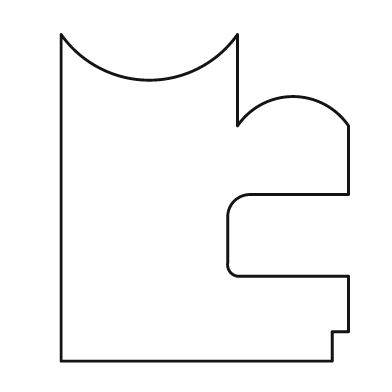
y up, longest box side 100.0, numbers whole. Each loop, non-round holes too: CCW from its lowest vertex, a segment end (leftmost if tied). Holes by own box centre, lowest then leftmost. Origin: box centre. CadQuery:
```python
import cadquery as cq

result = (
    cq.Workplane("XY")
    .moveTo(-44.0, -50.0)
    .lineTo(39.0, -50.0)
    .lineTo(39.0, -41.0)
    .lineTo(44.0, -41.0)
    .lineTo(44.0, -24.0)
    .lineTo(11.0, -24.0)
    .threePointArc((8.0, -23.0), (7.0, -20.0))
    .lineTo(7.0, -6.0)
    .threePointArc((9.0, -1.0), (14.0, 1.0))
    .lineTo(44.0, 1.0)
    .lineTo(44.0, 22.0)
    .threePointArc((27.0, 31.0), (10.0, 22.0))
    .lineTo(10.0, 50.0)
    .threePointArc((-17.0, 36.0), (-44.0, 50.0))
    .close()
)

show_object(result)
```